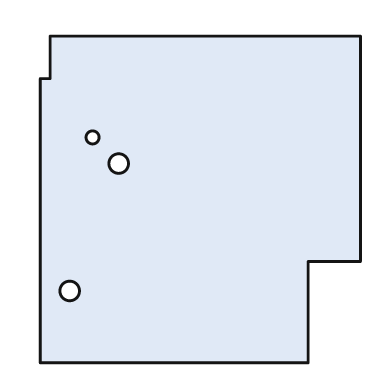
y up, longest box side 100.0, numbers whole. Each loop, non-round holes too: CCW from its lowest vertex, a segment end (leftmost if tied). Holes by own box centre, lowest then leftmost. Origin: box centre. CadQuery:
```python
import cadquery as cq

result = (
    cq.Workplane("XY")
    .moveTo(-49.0, -50.0)
    .lineTo(33.0, -50.0)
    .lineTo(33.0, -19.0)
    .lineTo(49.0, -19.0)
    .lineTo(49.0, 50.0)
    .lineTo(-46.0, 50.0)
    .lineTo(-46.0, 37.0)
    .lineTo(-49.0, 37.0)
    .close()
    .moveTo(-40.0, -28.0)
    .circle(3.0)
    .moveTo(-25.0, 11.0)
    .circle(3.0)
    .moveTo(-33.0, 19.0)
    .circle(2.0)
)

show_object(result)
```